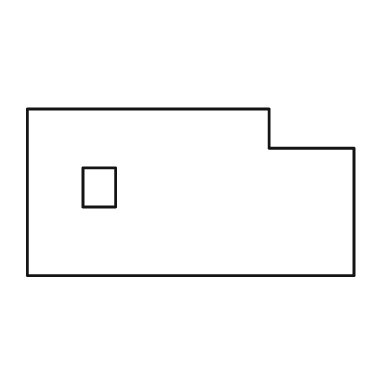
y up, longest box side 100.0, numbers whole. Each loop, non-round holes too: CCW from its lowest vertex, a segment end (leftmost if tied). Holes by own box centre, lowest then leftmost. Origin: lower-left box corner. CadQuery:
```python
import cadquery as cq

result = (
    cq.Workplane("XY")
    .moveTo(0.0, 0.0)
    .lineTo(100.0, 0.0)
    .lineTo(100.0, 39.0)
    .lineTo(74.0, 39.0)
    .lineTo(74.0, 51.0)
    .lineTo(0.0, 51.0)
    .close()
    .moveTo(17.0, 21.0)
    .lineTo(27.0, 21.0)
    .lineTo(27.0, 33.0)
    .lineTo(17.0, 33.0)
    .close()
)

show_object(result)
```